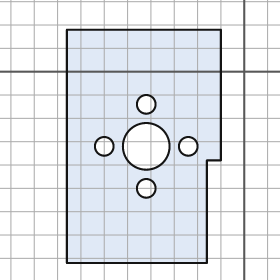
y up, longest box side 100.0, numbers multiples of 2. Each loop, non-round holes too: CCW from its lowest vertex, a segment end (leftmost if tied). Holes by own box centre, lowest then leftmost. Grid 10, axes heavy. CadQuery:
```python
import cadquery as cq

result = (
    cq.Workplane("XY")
    .moveTo(-76.0, -82.0)
    .lineTo(-16.0, -82.0)
    .lineTo(-16.0, -38.0)
    .lineTo(-10.0, -38.0)
    .lineTo(-10.0, 18.0)
    .lineTo(-76.0, 18.0)
    .close()
    .moveTo(-42.0, -50.0)
    .circle(4.0)
    .moveTo(-60.0, -32.0)
    .circle(4.0)
    .moveTo(-42.0, -32.0)
    .circle(10.0)
    .moveTo(-24.0, -32.0)
    .circle(4.0)
    .moveTo(-42.0, -14.0)
    .circle(4.0)
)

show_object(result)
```